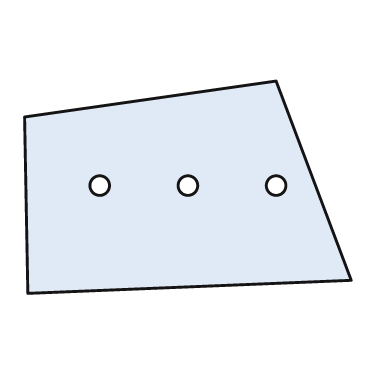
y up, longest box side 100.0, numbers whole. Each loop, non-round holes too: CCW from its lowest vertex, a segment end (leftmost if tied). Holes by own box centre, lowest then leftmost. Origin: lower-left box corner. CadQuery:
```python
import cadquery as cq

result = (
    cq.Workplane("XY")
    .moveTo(1.0, 0.0)
    .lineTo(100.0, 4.0)
    .lineTo(77.0, 65.0)
    .lineTo(0.0, 54.0)
    .close()
    .moveTo(23.0, 33.0)
    .circle(3.0)
    .moveTo(50.0, 33.0)
    .circle(3.0)
    .moveTo(77.0, 33.0)
    .circle(3.0)
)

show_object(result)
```